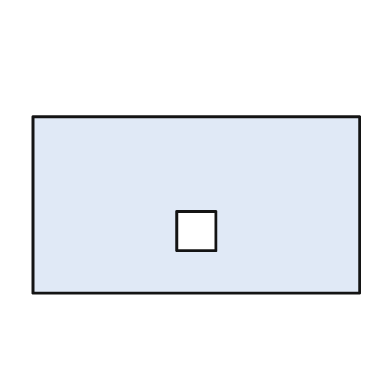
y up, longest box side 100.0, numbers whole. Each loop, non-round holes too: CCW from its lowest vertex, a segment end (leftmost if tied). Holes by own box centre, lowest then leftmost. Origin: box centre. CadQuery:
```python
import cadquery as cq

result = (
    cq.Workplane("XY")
    .moveTo(-50.0, -27.0)
    .lineTo(50.0, -27.0)
    .lineTo(50.0, 27.0)
    .lineTo(-50.0, 27.0)
    .close()
    .moveTo(-6.0, -14.0)
    .lineTo(6.0, -14.0)
    .lineTo(6.0, -2.0)
    .lineTo(-6.0, -2.0)
    .close()
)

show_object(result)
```